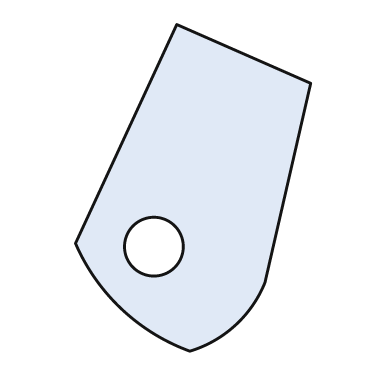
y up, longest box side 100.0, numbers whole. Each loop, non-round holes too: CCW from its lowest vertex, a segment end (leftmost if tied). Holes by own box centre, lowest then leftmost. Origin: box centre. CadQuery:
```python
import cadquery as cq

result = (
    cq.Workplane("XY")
    .moveTo(-1.0, -50.0)
    .threePointArc((13.0, -42.0), (22.0, -29.0))
    .lineTo(36.0, 32.0)
    .lineTo(-5.0, 50.0)
    .lineTo(-36.0, -17.0)
    .threePointArc((-22.0, -37.0), (-1.0, -50.0))
    .close()
    .moveTo(-12.0, -18.0)
    .circle(9.0)
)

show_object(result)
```